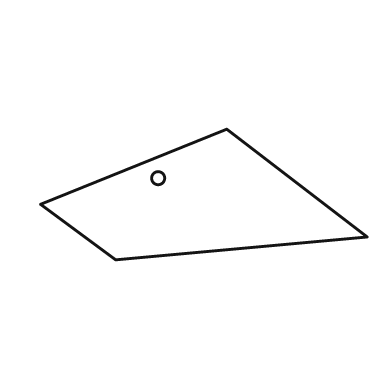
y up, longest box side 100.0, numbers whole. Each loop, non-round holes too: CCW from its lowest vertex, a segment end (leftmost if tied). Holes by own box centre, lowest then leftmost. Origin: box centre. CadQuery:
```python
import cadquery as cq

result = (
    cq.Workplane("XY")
    .moveTo(-27.0, -20.0)
    .lineTo(50.0, -13.0)
    .lineTo(7.0, 20.0)
    .lineTo(-50.0, -3.0)
    .close()
    .moveTo(-14.0, 5.0)
    .circle(2.0)
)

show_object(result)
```